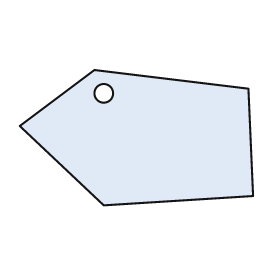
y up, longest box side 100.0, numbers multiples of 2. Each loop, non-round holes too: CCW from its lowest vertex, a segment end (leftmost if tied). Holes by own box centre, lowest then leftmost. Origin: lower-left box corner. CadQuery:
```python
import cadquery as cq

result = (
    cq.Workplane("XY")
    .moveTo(36.0, 0.0)
    .lineTo(100.0, 4.0)
    .lineTo(98.0, 50.0)
    .lineTo(32.0, 58.0)
    .lineTo(0.0, 34.0)
    .close()
    .moveTo(36.0, 48.0)
    .circle(4.0)
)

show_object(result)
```